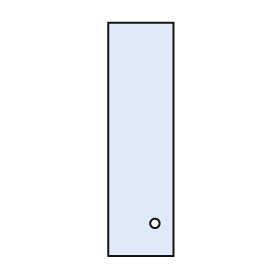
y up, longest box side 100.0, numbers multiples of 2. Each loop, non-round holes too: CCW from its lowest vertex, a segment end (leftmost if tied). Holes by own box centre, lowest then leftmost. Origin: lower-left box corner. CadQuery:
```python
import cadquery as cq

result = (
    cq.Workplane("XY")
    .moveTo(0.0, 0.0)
    .lineTo(28.0, 0.0)
    .lineTo(28.0, 100.0)
    .lineTo(0.0, 100.0)
    .close()
    .moveTo(20.0, 14.0)
    .circle(2.0)
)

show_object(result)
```